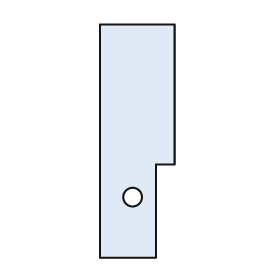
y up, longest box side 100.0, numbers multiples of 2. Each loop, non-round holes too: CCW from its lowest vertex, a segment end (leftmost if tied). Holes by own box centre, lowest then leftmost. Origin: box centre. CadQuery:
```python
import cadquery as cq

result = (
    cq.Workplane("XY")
    .moveTo(-16.0, -50.0)
    .lineTo(8.0, -50.0)
    .lineTo(8.0, -10.0)
    .lineTo(16.0, -10.0)
    .lineTo(16.0, 50.0)
    .lineTo(-16.0, 50.0)
    .close()
    .moveTo(-2.0, -24.0)
    .circle(4.0)
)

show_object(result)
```